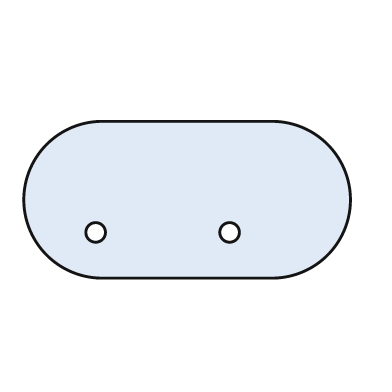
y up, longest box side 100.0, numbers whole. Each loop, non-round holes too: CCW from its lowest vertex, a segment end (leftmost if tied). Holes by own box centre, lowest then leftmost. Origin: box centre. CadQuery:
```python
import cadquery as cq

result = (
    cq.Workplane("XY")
    .moveTo(-26.0, -24.0)
    .lineTo(26.0, -24.0)
    .threePointArc((50.0, 0.0), (26.0, 24.0))
    .lineTo(-26.0, 24.0)
    .threePointArc((-50.0, 0.0), (-26.0, -24.0))
    .close()
    .moveTo(-28.0, -10.0)
    .circle(3.0)
    .moveTo(13.0, -10.0)
    .circle(3.0)
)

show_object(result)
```